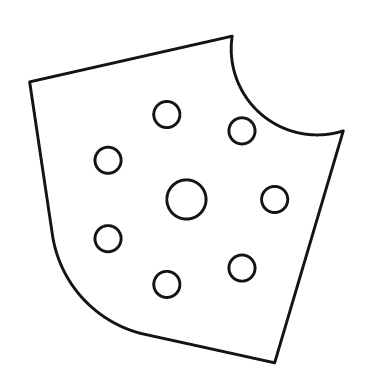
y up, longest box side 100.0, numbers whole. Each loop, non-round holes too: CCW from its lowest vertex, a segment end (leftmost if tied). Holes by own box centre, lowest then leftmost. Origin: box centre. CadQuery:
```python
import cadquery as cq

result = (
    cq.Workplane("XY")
    .moveTo(27.0, -50.0)
    .lineTo(48.0, 21.0)
    .threePointArc((23.0, 26.0), (14.0, 50.0))
    .lineTo(-48.0, 36.0)
    .lineTo(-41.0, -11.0)
    .threePointArc((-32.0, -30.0), (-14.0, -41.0))
    .close()
    .moveTo(-6.0, -26.0)
    .circle(4.0)
    .moveTo(17.0, -21.0)
    .circle(4.0)
    .moveTo(-24.0, -12.0)
    .circle(4.0)
    .moveTo(0.0, 0.0)
    .circle(6.0)
    .moveTo(27.0, 0.0)
    .circle(4.0)
    .moveTo(-24.0, 12.0)
    .circle(4.0)
    .moveTo(17.0, 21.0)
    .circle(4.0)
    .moveTo(-6.0, 26.0)
    .circle(4.0)
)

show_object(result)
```